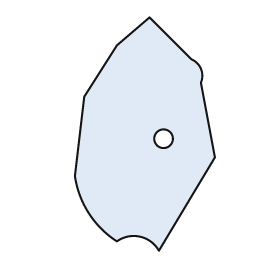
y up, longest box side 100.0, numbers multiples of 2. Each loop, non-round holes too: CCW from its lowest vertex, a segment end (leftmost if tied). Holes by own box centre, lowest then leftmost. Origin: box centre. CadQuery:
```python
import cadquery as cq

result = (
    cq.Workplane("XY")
    .moveTo(6.0, -50.0)
    .lineTo(30.0, -10.0)
    .lineTo(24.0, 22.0)
    .threePointArc((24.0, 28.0), (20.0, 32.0))
    .lineTo(2.0, 50.0)
    .lineTo(-12.0, 38.0)
    .lineTo(-26.0, 16.0)
    .lineTo(-30.0, -18.0)
    .threePointArc((-24.0, -34.0), (-12.0, -46.0))
    .threePointArc((-2.0, -44.0), (6.0, -50.0))
    .close()
    .moveTo(8.0, -2.0)
    .circle(4.0)
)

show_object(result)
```